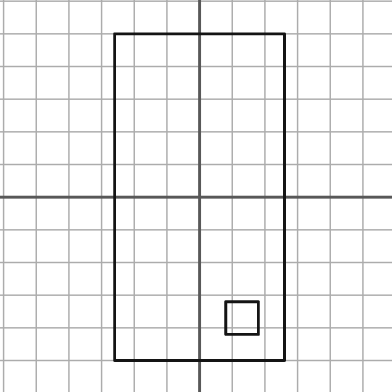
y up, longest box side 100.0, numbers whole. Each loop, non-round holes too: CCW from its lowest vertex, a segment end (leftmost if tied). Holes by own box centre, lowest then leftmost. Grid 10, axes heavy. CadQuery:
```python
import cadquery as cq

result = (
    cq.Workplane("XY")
    .moveTo(-26.0, -50.0)
    .lineTo(26.0, -50.0)
    .lineTo(26.0, 50.0)
    .lineTo(-26.0, 50.0)
    .close()
    .moveTo(8.0, -42.0)
    .lineTo(18.0, -42.0)
    .lineTo(18.0, -32.0)
    .lineTo(8.0, -32.0)
    .close()
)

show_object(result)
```